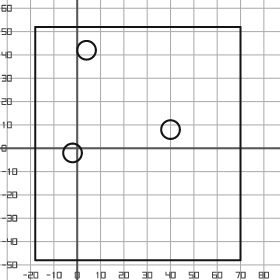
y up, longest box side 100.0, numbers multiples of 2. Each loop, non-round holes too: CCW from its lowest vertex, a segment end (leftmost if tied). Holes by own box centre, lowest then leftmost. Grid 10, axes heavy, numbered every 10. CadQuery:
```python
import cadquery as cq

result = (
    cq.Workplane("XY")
    .moveTo(-18.0, -48.0)
    .lineTo(70.0, -48.0)
    .lineTo(70.0, 52.0)
    .lineTo(-18.0, 52.0)
    .close()
    .moveTo(-2.0, -2.0)
    .circle(4.0)
    .moveTo(40.0, 8.0)
    .circle(4.0)
    .moveTo(4.0, 42.0)
    .circle(4.0)
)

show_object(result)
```